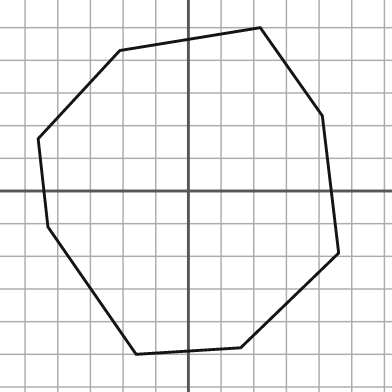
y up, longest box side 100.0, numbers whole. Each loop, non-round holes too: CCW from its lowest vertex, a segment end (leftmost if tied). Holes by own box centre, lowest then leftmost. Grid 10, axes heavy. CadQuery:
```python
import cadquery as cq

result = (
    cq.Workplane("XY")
    .moveTo(-16.0, -50.0)
    .lineTo(16.0, -48.0)
    .lineTo(46.0, -19.0)
    .lineTo(41.0, 23.0)
    .lineTo(22.0, 50.0)
    .lineTo(-21.0, 43.0)
    .lineTo(-46.0, 16.0)
    .lineTo(-43.0, -11.0)
    .close()
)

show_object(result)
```